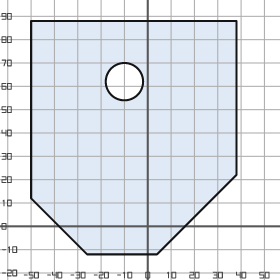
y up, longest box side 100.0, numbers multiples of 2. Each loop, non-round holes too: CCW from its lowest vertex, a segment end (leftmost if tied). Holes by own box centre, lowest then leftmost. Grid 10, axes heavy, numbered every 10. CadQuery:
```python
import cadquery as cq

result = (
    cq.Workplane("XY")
    .moveTo(-26.0, -12.0)
    .lineTo(4.0, -12.0)
    .lineTo(38.0, 22.0)
    .lineTo(38.0, 88.0)
    .lineTo(-50.0, 88.0)
    .lineTo(-50.0, 12.0)
    .close()
    .moveTo(-10.0, 62.0)
    .circle(8.0)
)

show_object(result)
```